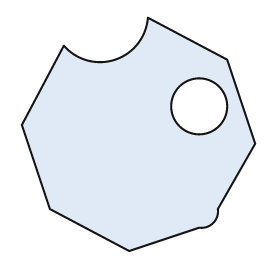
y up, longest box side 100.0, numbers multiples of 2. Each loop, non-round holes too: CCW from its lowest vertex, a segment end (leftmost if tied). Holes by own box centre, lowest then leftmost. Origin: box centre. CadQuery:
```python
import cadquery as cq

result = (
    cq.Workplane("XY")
    .moveTo(-4.0, -50.0)
    .lineTo(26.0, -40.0)
    .threePointArc((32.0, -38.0), (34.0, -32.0))
    .lineTo(50.0, -4.0)
    .lineTo(38.0, 32.0)
    .lineTo(4.0, 50.0)
    .threePointArc((-10.0, 32.0), (-32.0, 38.0))
    .lineTo(-50.0, 4.0)
    .lineTo(-38.0, -32.0)
    .close()
    .moveTo(26.0, 12.0)
    .circle(12.0)
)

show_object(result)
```